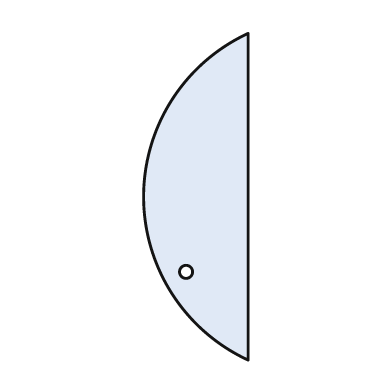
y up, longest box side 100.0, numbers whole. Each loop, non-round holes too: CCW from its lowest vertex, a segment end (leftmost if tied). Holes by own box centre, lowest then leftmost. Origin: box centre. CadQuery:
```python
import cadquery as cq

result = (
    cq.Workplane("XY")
    .moveTo(16.0, -50.0)
    .lineTo(16.0, 50.0)
    .threePointArc((-16.0, 0.0), (16.0, -50.0))
    .close()
    .moveTo(-3.0, -23.0)
    .circle(2.0)
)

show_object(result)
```